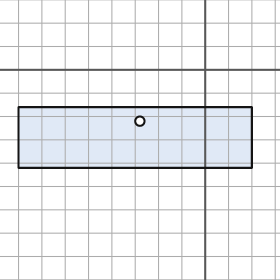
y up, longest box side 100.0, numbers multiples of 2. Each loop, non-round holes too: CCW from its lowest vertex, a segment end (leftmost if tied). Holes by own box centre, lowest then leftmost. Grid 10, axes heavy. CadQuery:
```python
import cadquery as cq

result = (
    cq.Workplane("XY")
    .moveTo(-80.0, -42.0)
    .lineTo(20.0, -42.0)
    .lineTo(20.0, -16.0)
    .lineTo(-80.0, -16.0)
    .close()
    .moveTo(-28.0, -22.0)
    .circle(2.0)
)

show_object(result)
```